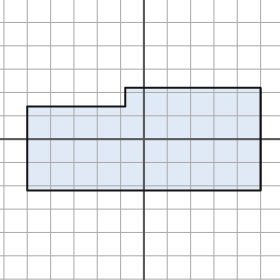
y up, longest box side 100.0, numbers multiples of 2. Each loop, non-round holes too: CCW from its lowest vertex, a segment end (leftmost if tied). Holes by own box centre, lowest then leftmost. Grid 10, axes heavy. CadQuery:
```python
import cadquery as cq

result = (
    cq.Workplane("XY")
    .moveTo(-50.0, -22.0)
    .lineTo(50.0, -22.0)
    .lineTo(50.0, 22.0)
    .lineTo(-8.0, 22.0)
    .lineTo(-8.0, 14.0)
    .lineTo(-50.0, 14.0)
    .close()
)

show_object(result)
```